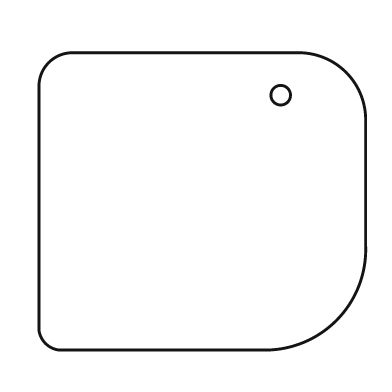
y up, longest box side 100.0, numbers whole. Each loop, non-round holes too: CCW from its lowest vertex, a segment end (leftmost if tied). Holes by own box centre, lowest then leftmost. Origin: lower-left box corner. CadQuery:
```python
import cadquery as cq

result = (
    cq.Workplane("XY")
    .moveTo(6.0, 0.0)
    .lineTo(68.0, 0.0)
    .threePointArc((91.0, 9.0), (100.0, 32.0))
    .lineTo(100.0, 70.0)
    .threePointArc((94.0, 85.0), (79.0, 91.0))
    .lineTo(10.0, 91.0)
    .threePointArc((3.0, 88.0), (0.0, 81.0))
    .lineTo(0.0, 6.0)
    .threePointArc((2.0, 2.0), (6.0, 0.0))
    .close()
    .moveTo(74.0, 78.0)
    .circle(3.0)
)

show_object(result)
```